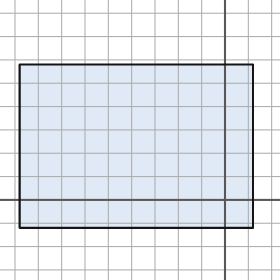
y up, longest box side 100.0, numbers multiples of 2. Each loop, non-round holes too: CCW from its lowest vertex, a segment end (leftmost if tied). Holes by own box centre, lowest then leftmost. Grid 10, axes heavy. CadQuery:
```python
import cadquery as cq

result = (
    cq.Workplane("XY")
    .moveTo(-88.0, -12.0)
    .lineTo(12.0, -12.0)
    .lineTo(12.0, 58.0)
    .lineTo(-88.0, 58.0)
    .close()
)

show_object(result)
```